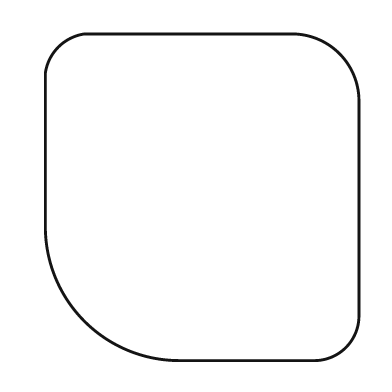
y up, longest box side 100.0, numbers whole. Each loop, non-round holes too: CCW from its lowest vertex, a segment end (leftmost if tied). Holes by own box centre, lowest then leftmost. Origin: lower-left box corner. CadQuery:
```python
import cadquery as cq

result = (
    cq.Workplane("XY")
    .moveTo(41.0, 0.0)
    .lineTo(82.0, 0.0)
    .threePointArc((92.0, 4.0), (96.0, 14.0))
    .lineTo(96.0, 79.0)
    .threePointArc((90.0, 94.0), (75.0, 100.0))
    .lineTo(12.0, 100.0)
    .threePointArc((4.0, 96.0), (0.0, 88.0))
    .lineTo(0.0, 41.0)
    .threePointArc((12.0, 12.0), (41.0, 0.0))
    .close()
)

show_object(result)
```